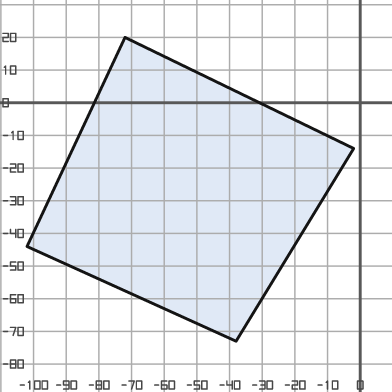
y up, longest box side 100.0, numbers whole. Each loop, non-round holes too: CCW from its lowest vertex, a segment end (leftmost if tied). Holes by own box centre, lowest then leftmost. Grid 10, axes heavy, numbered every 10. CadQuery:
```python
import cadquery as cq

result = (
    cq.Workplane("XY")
    .moveTo(-38.0, -73.0)
    .lineTo(-2.0, -14.0)
    .lineTo(-72.0, 20.0)
    .lineTo(-102.0, -44.0)
    .close()
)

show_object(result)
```